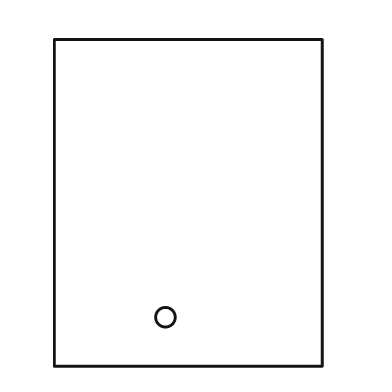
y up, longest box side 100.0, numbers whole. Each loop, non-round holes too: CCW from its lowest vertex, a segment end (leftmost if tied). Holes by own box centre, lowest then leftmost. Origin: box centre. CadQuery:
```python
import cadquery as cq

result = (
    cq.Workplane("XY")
    .moveTo(-41.0, -50.0)
    .lineTo(41.0, -50.0)
    .lineTo(41.0, 50.0)
    .lineTo(-41.0, 50.0)
    .close()
    .moveTo(-7.0, -35.0)
    .circle(3.0)
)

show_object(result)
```